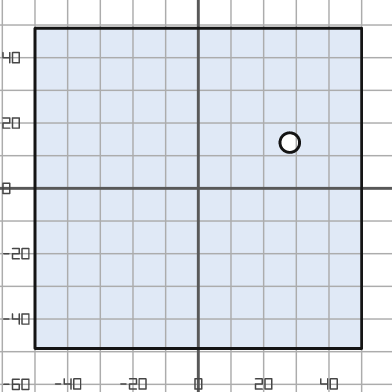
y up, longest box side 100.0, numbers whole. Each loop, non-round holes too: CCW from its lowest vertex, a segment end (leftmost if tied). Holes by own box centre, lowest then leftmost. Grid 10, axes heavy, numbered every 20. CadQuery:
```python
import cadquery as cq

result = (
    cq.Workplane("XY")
    .moveTo(-50.0, -49.0)
    .lineTo(50.0, -49.0)
    .lineTo(50.0, 49.0)
    .lineTo(-50.0, 49.0)
    .close()
    .moveTo(28.0, 14.0)
    .circle(3.0)
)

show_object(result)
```